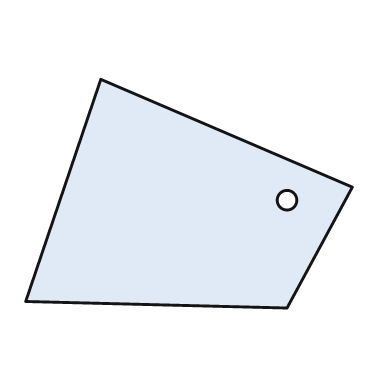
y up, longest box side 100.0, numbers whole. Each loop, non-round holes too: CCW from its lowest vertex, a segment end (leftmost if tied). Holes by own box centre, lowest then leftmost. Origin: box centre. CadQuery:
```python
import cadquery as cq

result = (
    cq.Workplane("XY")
    .moveTo(30.0, -35.0)
    .lineTo(50.0, 2.0)
    .lineTo(-27.0, 35.0)
    .lineTo(-50.0, -33.0)
    .close()
    .moveTo(30.0, -2.0)
    .circle(3.0)
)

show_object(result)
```